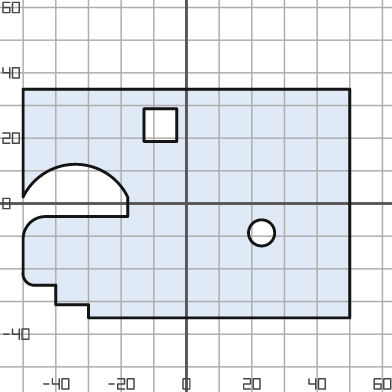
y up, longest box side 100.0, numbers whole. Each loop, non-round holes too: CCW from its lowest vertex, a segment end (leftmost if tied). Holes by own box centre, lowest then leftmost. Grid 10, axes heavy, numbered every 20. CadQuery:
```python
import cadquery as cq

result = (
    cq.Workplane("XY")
    .moveTo(-30.0, -35.0)
    .lineTo(50.0, -35.0)
    .lineTo(50.0, 35.0)
    .lineTo(-50.0, 35.0)
    .lineTo(-50.0, 2.0)
    .threePointArc((-34.0, 12.0), (-18.0, 2.0))
    .lineTo(-18.0, -4.0)
    .lineTo(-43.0, -4.0)
    .threePointArc((-48.0, -6.0), (-50.0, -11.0))
    .lineTo(-50.0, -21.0)
    .threePointArc((-49.0, -24.0), (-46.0, -25.0))
    .lineTo(-40.0, -25.0)
    .lineTo(-40.0, -31.0)
    .lineTo(-30.0, -31.0)
    .close()
    .moveTo(23.0, -9.0)
    .circle(4.0)
    .moveTo(-13.0, 19.0)
    .lineTo(-3.0, 19.0)
    .lineTo(-3.0, 29.0)
    .lineTo(-13.0, 29.0)
    .close()
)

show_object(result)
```